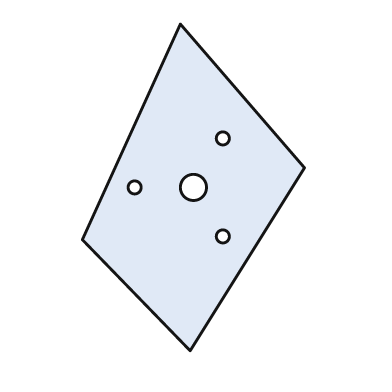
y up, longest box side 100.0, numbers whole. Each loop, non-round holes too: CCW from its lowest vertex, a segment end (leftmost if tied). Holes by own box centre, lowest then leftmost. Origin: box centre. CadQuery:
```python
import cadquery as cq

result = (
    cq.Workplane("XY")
    .moveTo(-1.0, -50.0)
    .lineTo(34.0, 6.0)
    .lineTo(-4.0, 50.0)
    .lineTo(-34.0, -16.0)
    .close()
    .moveTo(9.0, -15.0)
    .circle(2.0)
    .moveTo(-18.0, 0.0)
    .circle(2.0)
    .moveTo(0.0, 0.0)
    .circle(4.0)
    .moveTo(9.0, 15.0)
    .circle(2.0)
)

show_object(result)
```